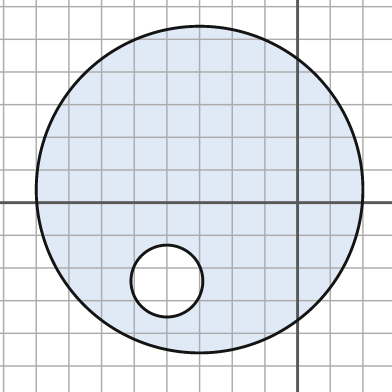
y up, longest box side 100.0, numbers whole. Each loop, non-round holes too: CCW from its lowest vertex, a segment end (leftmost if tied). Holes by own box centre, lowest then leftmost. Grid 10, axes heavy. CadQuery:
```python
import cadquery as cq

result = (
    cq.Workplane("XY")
    .moveTo(-30.0, 4.0)
    .circle(50.0)
    .moveTo(-40.0, -24.0)
    .circle(11.0)
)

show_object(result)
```